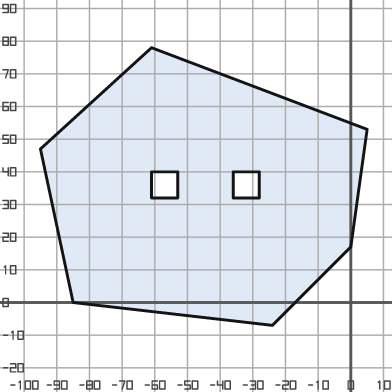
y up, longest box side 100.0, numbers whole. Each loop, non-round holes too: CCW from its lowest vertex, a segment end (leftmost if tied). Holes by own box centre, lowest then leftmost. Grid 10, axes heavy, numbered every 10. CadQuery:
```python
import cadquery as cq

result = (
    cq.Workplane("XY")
    .moveTo(-24.0, -7.0)
    .lineTo(0.0, 17.0)
    .lineTo(5.0, 53.0)
    .lineTo(-61.0, 78.0)
    .lineTo(-95.0, 47.0)
    .lineTo(-85.0, 0.0)
    .close()
    .moveTo(-61.0, 32.0)
    .lineTo(-53.0, 32.0)
    .lineTo(-53.0, 40.0)
    .lineTo(-61.0, 40.0)
    .close()
    .moveTo(-36.0, 32.0)
    .lineTo(-28.0, 32.0)
    .lineTo(-28.0, 40.0)
    .lineTo(-36.0, 40.0)
    .close()
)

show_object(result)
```